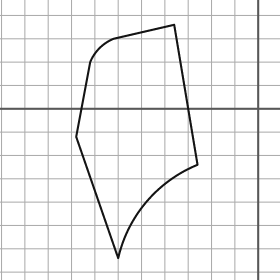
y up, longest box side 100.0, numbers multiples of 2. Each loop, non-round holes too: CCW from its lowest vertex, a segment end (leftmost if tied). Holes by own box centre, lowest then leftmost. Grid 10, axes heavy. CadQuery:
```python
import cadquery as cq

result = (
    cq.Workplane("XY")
    .moveTo(-60.0, -64.0)
    .threePointArc((-48.0, -40.0), (-26.0, -24.0))
    .lineTo(-36.0, 36.0)
    .lineTo(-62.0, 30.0)
    .threePointArc((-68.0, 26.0), (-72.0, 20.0))
    .lineTo(-78.0, -12.0)
    .close()
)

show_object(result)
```